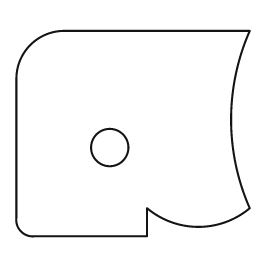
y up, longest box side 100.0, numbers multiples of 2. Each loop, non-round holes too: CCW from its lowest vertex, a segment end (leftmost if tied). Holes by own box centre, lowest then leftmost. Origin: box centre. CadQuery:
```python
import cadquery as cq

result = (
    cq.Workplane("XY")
    .moveTo(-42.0, -44.0)
    .lineTo(6.0, -44.0)
    .lineTo(6.0, -32.0)
    .threePointArc((28.0, -40.0), (50.0, -32.0))
    .threePointArc((42.0, 6.0), (50.0, 44.0))
    .lineTo(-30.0, 44.0)
    .threePointArc((-44.0, 38.0), (-50.0, 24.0))
    .lineTo(-50.0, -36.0)
    .threePointArc((-48.0, -42.0), (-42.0, -44.0))
    .close()
    .moveTo(-10.0, -6.0)
    .circle(8.0)
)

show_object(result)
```